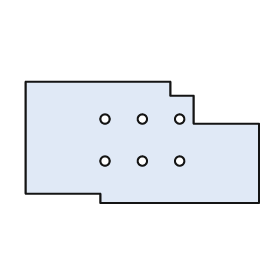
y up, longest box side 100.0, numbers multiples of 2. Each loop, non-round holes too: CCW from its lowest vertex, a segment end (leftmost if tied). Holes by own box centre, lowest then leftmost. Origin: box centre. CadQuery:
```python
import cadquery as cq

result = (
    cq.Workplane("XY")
    .moveTo(-18.0, -26.0)
    .lineTo(50.0, -26.0)
    .lineTo(50.0, 8.0)
    .lineTo(22.0, 8.0)
    .lineTo(22.0, 20.0)
    .lineTo(12.0, 20.0)
    .lineTo(12.0, 26.0)
    .lineTo(-50.0, 26.0)
    .lineTo(-50.0, -22.0)
    .lineTo(-18.0, -22.0)
    .close()
    .moveTo(-16.0, -8.0)
    .circle(2.0)
    .moveTo(0.0, -8.0)
    .circle(2.0)
    .moveTo(16.0, -8.0)
    .circle(2.0)
    .moveTo(-16.0, 10.0)
    .circle(2.0)
    .moveTo(0.0, 10.0)
    .circle(2.0)
    .moveTo(16.0, 10.0)
    .circle(2.0)
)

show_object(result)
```